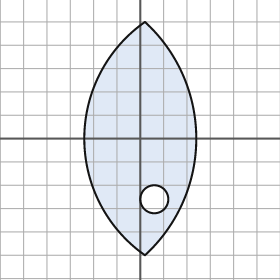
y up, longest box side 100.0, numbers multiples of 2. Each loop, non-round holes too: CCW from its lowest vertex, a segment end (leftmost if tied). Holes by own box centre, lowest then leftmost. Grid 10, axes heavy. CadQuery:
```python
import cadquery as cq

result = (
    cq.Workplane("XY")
    .moveTo(2.0, -50.0)
    .threePointArc((24.0, 0.0), (2.0, 50.0))
    .threePointArc((-24.0, 0.0), (2.0, -50.0))
    .close()
    .moveTo(6.0, -26.0)
    .circle(6.0)
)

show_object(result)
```